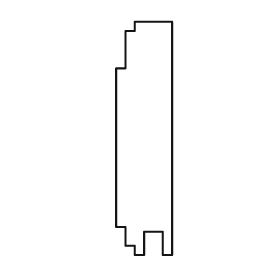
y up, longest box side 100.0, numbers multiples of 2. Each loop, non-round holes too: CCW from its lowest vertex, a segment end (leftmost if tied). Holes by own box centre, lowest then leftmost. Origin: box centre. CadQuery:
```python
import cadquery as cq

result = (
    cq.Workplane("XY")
    .moveTo(-4.0, -50.0)
    .lineTo(0.0, -50.0)
    .lineTo(0.0, -40.0)
    .lineTo(8.0, -40.0)
    .lineTo(8.0, -50.0)
    .lineTo(12.0, -50.0)
    .lineTo(12.0, 50.0)
    .lineTo(-4.0, 50.0)
    .lineTo(-4.0, 46.0)
    .lineTo(-8.0, 46.0)
    .lineTo(-8.0, 30.0)
    .lineTo(-12.0, 30.0)
    .lineTo(-12.0, -38.0)
    .lineTo(-8.0, -38.0)
    .lineTo(-8.0, -46.0)
    .lineTo(-4.0, -46.0)
    .close()
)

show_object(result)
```